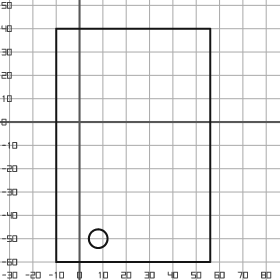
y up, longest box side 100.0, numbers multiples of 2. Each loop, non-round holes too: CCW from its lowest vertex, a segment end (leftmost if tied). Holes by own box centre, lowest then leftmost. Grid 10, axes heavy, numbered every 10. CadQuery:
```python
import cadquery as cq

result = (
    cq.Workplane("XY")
    .moveTo(-10.0, -60.0)
    .lineTo(56.0, -60.0)
    .lineTo(56.0, 40.0)
    .lineTo(-10.0, 40.0)
    .close()
    .moveTo(8.0, -50.0)
    .circle(4.0)
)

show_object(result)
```